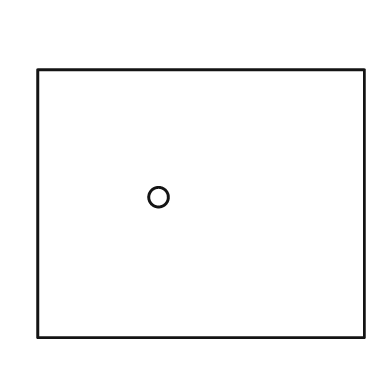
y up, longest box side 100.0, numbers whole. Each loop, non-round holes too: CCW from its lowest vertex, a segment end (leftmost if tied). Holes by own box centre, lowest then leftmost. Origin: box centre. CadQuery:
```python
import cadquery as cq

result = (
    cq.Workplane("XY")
    .moveTo(-50.0, -41.0)
    .lineTo(50.0, -41.0)
    .lineTo(50.0, 41.0)
    .lineTo(-50.0, 41.0)
    .close()
    .moveTo(-13.0, 2.0)
    .circle(3.0)
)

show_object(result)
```